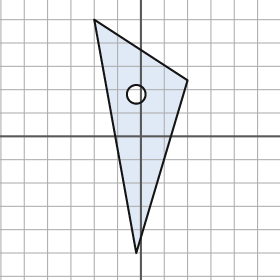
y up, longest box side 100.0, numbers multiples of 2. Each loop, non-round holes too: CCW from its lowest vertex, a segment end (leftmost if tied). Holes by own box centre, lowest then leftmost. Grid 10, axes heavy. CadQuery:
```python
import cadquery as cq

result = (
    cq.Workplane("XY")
    .moveTo(-2.0, -50.0)
    .lineTo(20.0, 24.0)
    .lineTo(-20.0, 50.0)
    .close()
    .moveTo(-2.0, 18.0)
    .circle(4.0)
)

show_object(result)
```